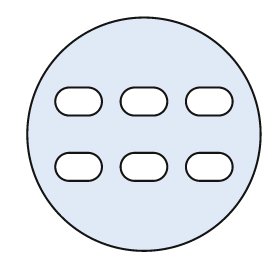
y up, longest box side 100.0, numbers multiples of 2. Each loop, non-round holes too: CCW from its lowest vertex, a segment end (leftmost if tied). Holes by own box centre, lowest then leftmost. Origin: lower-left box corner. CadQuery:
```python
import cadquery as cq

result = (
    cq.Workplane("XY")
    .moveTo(50.0, 50.0)
    .circle(50.0)
    .moveTo(18.0, 30.0)
    .lineTo(26.0, 30.0)
    .threePointArc((32.0, 36.0), (26.0, 42.0))
    .lineTo(18.0, 42.0)
    .threePointArc((12.0, 36.0), (18.0, 30.0))
    .close()
    .moveTo(46.0, 30.0)
    .lineTo(54.0, 30.0)
    .threePointArc((60.0, 36.0), (54.0, 42.0))
    .lineTo(46.0, 42.0)
    .threePointArc((40.0, 36.0), (46.0, 30.0))
    .close()
    .moveTo(74.0, 30.0)
    .lineTo(82.0, 30.0)
    .threePointArc((88.0, 36.0), (82.0, 42.0))
    .lineTo(74.0, 42.0)
    .threePointArc((68.0, 36.0), (74.0, 30.0))
    .close()
    .moveTo(18.0, 58.0)
    .lineTo(26.0, 58.0)
    .threePointArc((32.0, 64.0), (26.0, 70.0))
    .lineTo(18.0, 70.0)
    .threePointArc((12.0, 64.0), (18.0, 58.0))
    .close()
    .moveTo(46.0, 58.0)
    .lineTo(54.0, 58.0)
    .threePointArc((60.0, 64.0), (54.0, 70.0))
    .lineTo(46.0, 70.0)
    .threePointArc((40.0, 64.0), (46.0, 58.0))
    .close()
    .moveTo(74.0, 58.0)
    .lineTo(82.0, 58.0)
    .threePointArc((88.0, 64.0), (82.0, 70.0))
    .lineTo(74.0, 70.0)
    .threePointArc((68.0, 64.0), (74.0, 58.0))
    .close()
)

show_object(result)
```